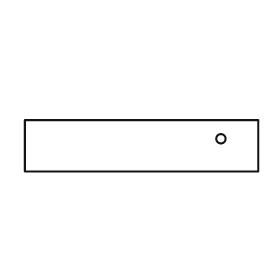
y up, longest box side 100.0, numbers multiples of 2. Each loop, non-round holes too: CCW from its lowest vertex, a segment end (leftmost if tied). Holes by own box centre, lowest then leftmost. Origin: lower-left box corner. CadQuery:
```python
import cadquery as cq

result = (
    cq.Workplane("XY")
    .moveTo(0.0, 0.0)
    .lineTo(100.0, 0.0)
    .lineTo(100.0, 22.0)
    .lineTo(0.0, 22.0)
    .close()
    .moveTo(84.0, 14.0)
    .circle(2.0)
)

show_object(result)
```